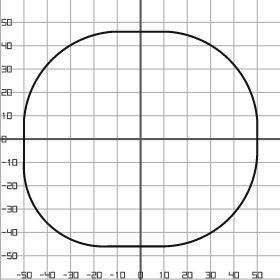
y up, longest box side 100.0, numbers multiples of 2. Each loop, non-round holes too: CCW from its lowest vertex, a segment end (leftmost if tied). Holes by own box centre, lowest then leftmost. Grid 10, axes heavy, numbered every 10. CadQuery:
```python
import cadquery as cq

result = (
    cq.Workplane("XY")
    .moveTo(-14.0, -46.0)
    .lineTo(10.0, -46.0)
    .threePointArc((38.0, -34.0), (50.0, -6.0))
    .lineTo(50.0, 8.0)
    .threePointArc((38.0, 34.0), (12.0, 46.0))
    .lineTo(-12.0, 46.0)
    .threePointArc((-38.0, 34.0), (-50.0, 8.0))
    .lineTo(-50.0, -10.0)
    .threePointArc((-40.0, -36.0), (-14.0, -46.0))
    .close()
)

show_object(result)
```